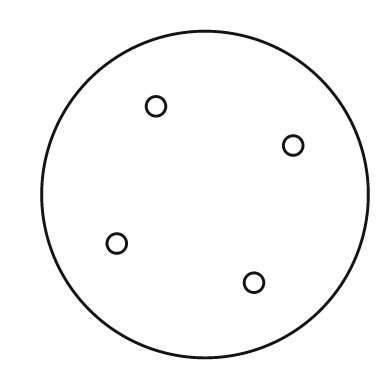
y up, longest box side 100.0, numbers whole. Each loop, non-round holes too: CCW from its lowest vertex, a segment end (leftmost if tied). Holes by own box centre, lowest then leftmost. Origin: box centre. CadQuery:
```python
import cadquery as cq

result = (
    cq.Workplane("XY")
    .moveTo(0.0, 0.0)
    .circle(50.0)
    .moveTo(15.0, -27.0)
    .circle(3.0)
    .moveTo(-27.0, -15.0)
    .circle(3.0)
    .moveTo(27.0, 15.0)
    .circle(3.0)
    .moveTo(-15.0, 27.0)
    .circle(3.0)
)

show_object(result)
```